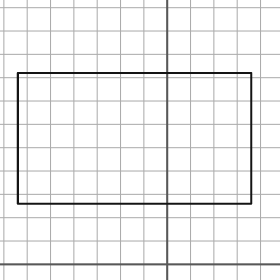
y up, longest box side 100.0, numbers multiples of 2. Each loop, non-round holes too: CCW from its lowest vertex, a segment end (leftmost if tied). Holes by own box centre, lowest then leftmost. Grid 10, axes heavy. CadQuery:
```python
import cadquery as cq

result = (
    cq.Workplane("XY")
    .moveTo(-64.0, 26.0)
    .lineTo(36.0, 26.0)
    .lineTo(36.0, 82.0)
    .lineTo(-64.0, 82.0)
    .close()
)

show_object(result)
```